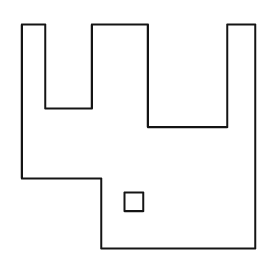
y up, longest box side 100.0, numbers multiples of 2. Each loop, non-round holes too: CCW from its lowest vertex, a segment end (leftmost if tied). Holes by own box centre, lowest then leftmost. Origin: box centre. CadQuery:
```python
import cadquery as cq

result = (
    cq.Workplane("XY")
    .moveTo(-16.0, -48.0)
    .lineTo(50.0, -48.0)
    .lineTo(50.0, 48.0)
    .lineTo(38.0, 48.0)
    .lineTo(38.0, 4.0)
    .lineTo(4.0, 4.0)
    .lineTo(4.0, 48.0)
    .lineTo(-20.0, 48.0)
    .lineTo(-20.0, 12.0)
    .lineTo(-40.0, 12.0)
    .lineTo(-40.0, 48.0)
    .lineTo(-50.0, 48.0)
    .lineTo(-50.0, -18.0)
    .lineTo(-16.0, -18.0)
    .close()
    .moveTo(-6.0, -32.0)
    .lineTo(2.0, -32.0)
    .lineTo(2.0, -24.0)
    .lineTo(-6.0, -24.0)
    .close()
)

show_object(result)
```